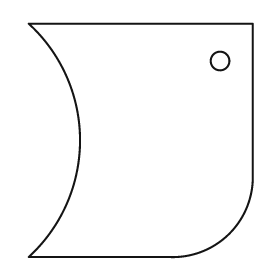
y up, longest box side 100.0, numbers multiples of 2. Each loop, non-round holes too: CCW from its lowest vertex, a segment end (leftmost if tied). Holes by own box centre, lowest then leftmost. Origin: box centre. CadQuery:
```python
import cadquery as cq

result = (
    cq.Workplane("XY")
    .moveTo(-48.0, -50.0)
    .lineTo(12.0, -50.0)
    .threePointArc((38.0, -40.0), (48.0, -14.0))
    .lineTo(48.0, 50.0)
    .lineTo(-48.0, 50.0)
    .threePointArc((-26.0, 0.0), (-48.0, -50.0))
    .close()
    .moveTo(34.0, 34.0)
    .circle(4.0)
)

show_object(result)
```